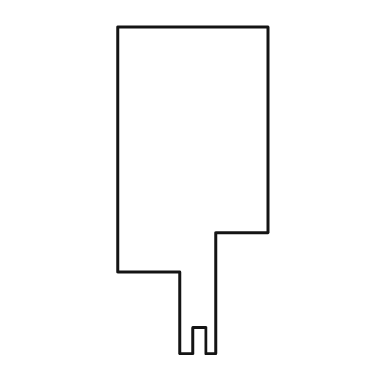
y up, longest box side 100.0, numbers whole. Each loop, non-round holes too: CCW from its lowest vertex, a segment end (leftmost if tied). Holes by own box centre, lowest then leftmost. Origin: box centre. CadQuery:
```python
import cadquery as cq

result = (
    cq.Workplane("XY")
    .moveTo(-4.0, -50.0)
    .lineTo(0.0, -50.0)
    .lineTo(0.0, -42.0)
    .lineTo(4.0, -42.0)
    .lineTo(4.0, -50.0)
    .lineTo(7.0, -50.0)
    .lineTo(7.0, -13.0)
    .lineTo(23.0, -13.0)
    .lineTo(23.0, 50.0)
    .lineTo(-23.0, 50.0)
    .lineTo(-23.0, -25.0)
    .lineTo(-4.0, -25.0)
    .close()
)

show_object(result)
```